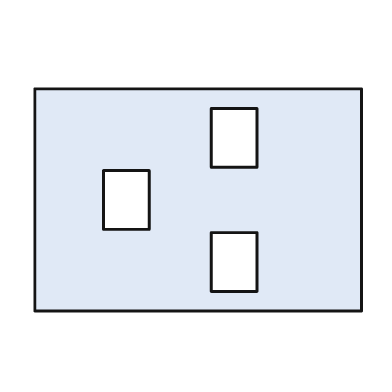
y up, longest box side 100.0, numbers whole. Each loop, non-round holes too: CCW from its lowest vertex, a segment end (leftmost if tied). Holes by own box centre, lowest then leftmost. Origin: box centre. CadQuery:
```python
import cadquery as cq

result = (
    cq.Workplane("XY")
    .moveTo(-50.0, -34.0)
    .lineTo(50.0, -34.0)
    .lineTo(50.0, 34.0)
    .lineTo(-50.0, 34.0)
    .close()
    .moveTo(4.0, -28.0)
    .lineTo(18.0, -28.0)
    .lineTo(18.0, -10.0)
    .lineTo(4.0, -10.0)
    .close()
    .moveTo(-29.0, -9.0)
    .lineTo(-15.0, -9.0)
    .lineTo(-15.0, 9.0)
    .lineTo(-29.0, 9.0)
    .close()
    .moveTo(4.0, 10.0)
    .lineTo(18.0, 10.0)
    .lineTo(18.0, 28.0)
    .lineTo(4.0, 28.0)
    .close()
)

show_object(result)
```